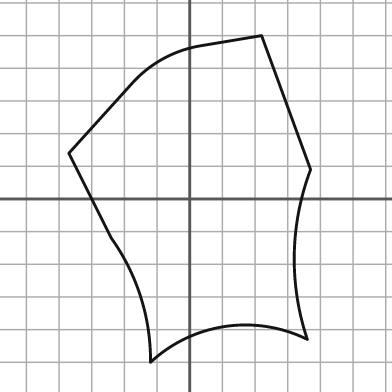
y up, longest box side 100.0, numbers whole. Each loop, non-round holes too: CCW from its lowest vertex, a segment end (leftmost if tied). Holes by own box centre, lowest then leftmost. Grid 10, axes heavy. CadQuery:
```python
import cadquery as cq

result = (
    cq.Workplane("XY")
    .moveTo(-12.0, -50.0)
    .threePointArc((11.0, -39.0), (36.0, -43.0))
    .threePointArc((32.0, -17.0), (37.0, 9.0))
    .lineTo(22.0, 50.0)
    .lineTo(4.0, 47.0)
    .threePointArc((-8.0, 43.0), (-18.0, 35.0))
    .lineTo(-37.0, 14.0)
    .lineTo(-24.0, -12.0)
    .threePointArc((-15.0, -30.0), (-12.0, -50.0))
    .close()
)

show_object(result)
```